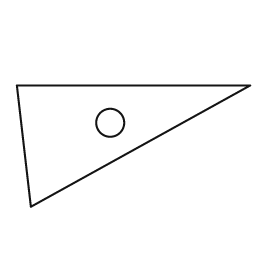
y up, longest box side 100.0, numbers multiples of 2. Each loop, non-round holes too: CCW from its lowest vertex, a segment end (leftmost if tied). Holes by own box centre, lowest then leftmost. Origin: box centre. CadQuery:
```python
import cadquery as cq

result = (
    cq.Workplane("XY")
    .moveTo(-44.0, -26.0)
    .lineTo(50.0, 26.0)
    .lineTo(-50.0, 26.0)
    .close()
    .moveTo(-10.0, 10.0)
    .circle(6.0)
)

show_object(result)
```